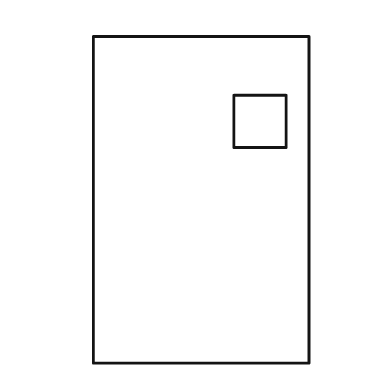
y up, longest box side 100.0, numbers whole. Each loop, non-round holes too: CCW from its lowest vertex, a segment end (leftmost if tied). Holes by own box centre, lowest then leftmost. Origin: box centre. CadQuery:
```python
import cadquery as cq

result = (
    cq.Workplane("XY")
    .moveTo(-33.0, -50.0)
    .lineTo(33.0, -50.0)
    .lineTo(33.0, 50.0)
    .lineTo(-33.0, 50.0)
    .close()
    .moveTo(10.0, 16.0)
    .lineTo(26.0, 16.0)
    .lineTo(26.0, 32.0)
    .lineTo(10.0, 32.0)
    .close()
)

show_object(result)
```